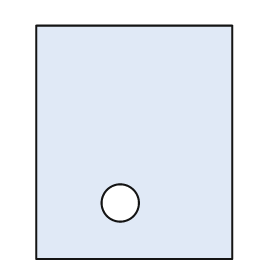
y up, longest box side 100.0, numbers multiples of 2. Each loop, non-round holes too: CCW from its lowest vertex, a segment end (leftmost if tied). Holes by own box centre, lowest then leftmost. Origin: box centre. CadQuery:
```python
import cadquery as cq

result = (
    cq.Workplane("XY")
    .moveTo(-42.0, -50.0)
    .lineTo(42.0, -50.0)
    .lineTo(42.0, 50.0)
    .lineTo(-42.0, 50.0)
    .close()
    .moveTo(-6.0, -26.0)
    .circle(8.0)
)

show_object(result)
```